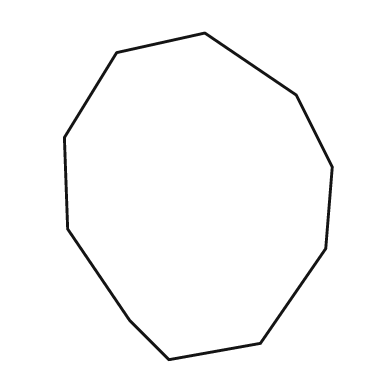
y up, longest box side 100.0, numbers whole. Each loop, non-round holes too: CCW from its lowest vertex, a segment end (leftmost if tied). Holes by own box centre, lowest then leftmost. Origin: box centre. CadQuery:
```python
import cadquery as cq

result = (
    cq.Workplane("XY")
    .moveTo(-9.0, -50.0)
    .lineTo(19.0, -45.0)
    .lineTo(39.0, -16.0)
    .lineTo(41.0, 9.0)
    .lineTo(30.0, 31.0)
    .lineTo(2.0, 50.0)
    .lineTo(-25.0, 44.0)
    .lineTo(-41.0, 18.0)
    .lineTo(-40.0, -10.0)
    .lineTo(-21.0, -38.0)
    .close()
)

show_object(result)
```